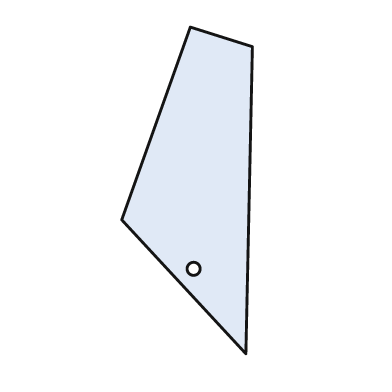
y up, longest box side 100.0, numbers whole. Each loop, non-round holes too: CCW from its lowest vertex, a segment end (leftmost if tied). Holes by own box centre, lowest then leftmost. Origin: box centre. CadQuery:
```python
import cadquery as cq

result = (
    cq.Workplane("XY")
    .moveTo(18.0, -50.0)
    .lineTo(20.0, 44.0)
    .lineTo(1.0, 50.0)
    .lineTo(-20.0, -9.0)
    .close()
    .moveTo(2.0, -24.0)
    .circle(2.0)
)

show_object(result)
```